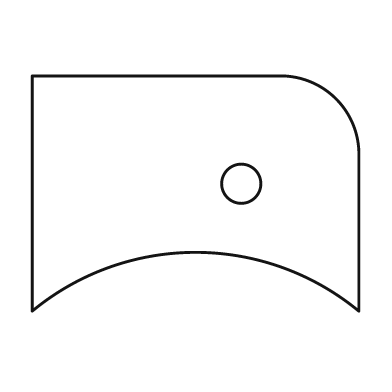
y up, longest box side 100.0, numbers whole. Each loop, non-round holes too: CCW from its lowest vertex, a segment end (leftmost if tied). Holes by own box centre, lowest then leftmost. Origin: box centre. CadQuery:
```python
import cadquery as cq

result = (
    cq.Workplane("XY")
    .moveTo(-50.0, -36.0)
    .threePointArc((0.0, -18.0), (50.0, -36.0))
    .lineTo(50.0, 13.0)
    .threePointArc((43.0, 29.0), (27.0, 36.0))
    .lineTo(-50.0, 36.0)
    .close()
    .moveTo(14.0, 3.0)
    .circle(6.0)
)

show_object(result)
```